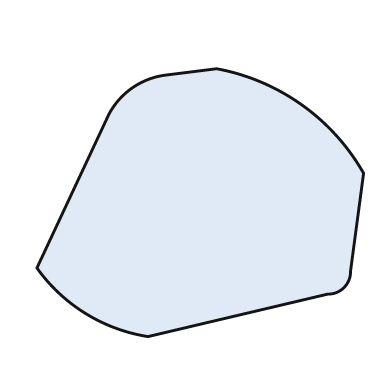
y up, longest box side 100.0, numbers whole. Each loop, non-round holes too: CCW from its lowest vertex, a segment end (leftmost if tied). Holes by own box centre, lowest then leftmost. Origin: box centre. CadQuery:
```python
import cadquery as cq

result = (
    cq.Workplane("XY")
    .moveTo(-16.0, -41.0)
    .lineTo(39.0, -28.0)
    .threePointArc((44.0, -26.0), (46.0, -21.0))
    .lineTo(50.0, 9.0)
    .threePointArc((31.0, 30.0), (5.0, 41.0))
    .lineTo(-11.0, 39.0)
    .threePointArc((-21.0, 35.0), (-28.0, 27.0))
    .lineTo(-50.0, -20.0)
    .threePointArc((-35.0, -34.0), (-16.0, -41.0))
    .close()
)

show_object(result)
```